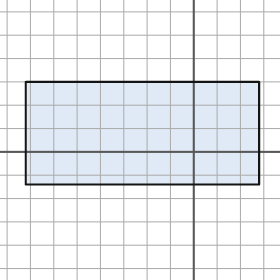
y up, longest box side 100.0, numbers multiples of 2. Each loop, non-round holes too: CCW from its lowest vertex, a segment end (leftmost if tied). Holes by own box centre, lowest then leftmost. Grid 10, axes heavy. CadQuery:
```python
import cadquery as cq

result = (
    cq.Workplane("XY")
    .moveTo(-72.0, -14.0)
    .lineTo(28.0, -14.0)
    .lineTo(28.0, 30.0)
    .lineTo(-72.0, 30.0)
    .close()
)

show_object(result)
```